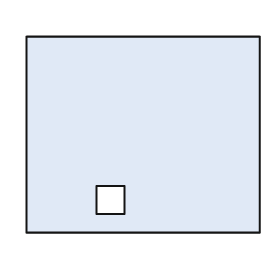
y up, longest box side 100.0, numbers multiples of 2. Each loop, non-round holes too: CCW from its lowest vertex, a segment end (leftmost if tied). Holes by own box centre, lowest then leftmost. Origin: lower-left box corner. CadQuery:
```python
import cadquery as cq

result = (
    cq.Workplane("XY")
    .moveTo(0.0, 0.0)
    .lineTo(100.0, 0.0)
    .lineTo(100.0, 84.0)
    .lineTo(0.0, 84.0)
    .close()
    .moveTo(30.0, 8.0)
    .lineTo(42.0, 8.0)
    .lineTo(42.0, 20.0)
    .lineTo(30.0, 20.0)
    .close()
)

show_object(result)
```